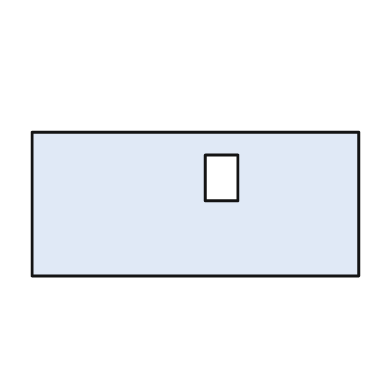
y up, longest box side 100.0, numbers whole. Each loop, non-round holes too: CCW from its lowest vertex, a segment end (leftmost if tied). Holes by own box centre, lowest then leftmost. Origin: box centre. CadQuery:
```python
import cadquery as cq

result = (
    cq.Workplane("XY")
    .moveTo(-50.0, -22.0)
    .lineTo(50.0, -22.0)
    .lineTo(50.0, 22.0)
    .lineTo(-50.0, 22.0)
    .close()
    .moveTo(3.0, 1.0)
    .lineTo(13.0, 1.0)
    .lineTo(13.0, 15.0)
    .lineTo(3.0, 15.0)
    .close()
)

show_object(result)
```